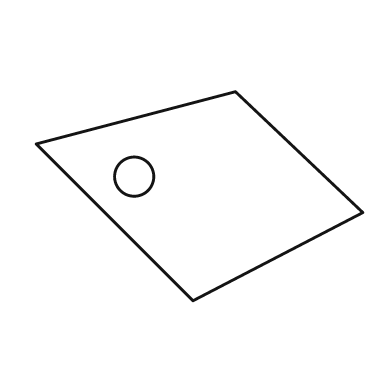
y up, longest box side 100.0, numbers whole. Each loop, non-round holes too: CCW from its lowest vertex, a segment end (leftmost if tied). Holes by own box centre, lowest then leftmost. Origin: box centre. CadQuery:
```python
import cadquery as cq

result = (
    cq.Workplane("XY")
    .moveTo(-2.0, -32.0)
    .lineTo(50.0, -5.0)
    .lineTo(11.0, 32.0)
    .lineTo(-50.0, 16.0)
    .close()
    .moveTo(-20.0, 6.0)
    .circle(6.0)
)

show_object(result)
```